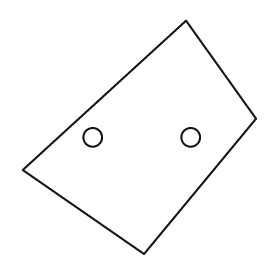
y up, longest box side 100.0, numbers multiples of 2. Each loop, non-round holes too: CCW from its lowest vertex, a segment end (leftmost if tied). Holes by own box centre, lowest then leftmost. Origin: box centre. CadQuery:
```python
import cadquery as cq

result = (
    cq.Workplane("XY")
    .moveTo(2.0, -50.0)
    .lineTo(50.0, 8.0)
    .lineTo(20.0, 50.0)
    .lineTo(-50.0, -14.0)
    .close()
    .moveTo(-20.0, 0.0)
    .circle(4.0)
    .moveTo(22.0, 0.0)
    .circle(4.0)
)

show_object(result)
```